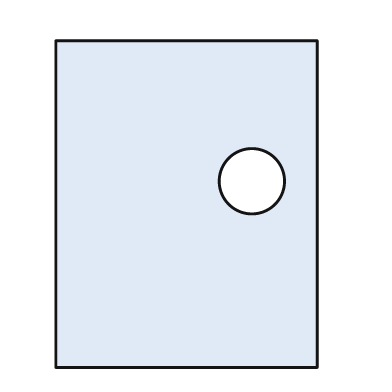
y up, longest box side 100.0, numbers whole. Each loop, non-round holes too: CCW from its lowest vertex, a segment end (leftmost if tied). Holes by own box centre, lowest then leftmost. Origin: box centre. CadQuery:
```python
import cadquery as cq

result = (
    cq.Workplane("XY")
    .moveTo(-40.0, -50.0)
    .lineTo(40.0, -50.0)
    .lineTo(40.0, 50.0)
    .lineTo(-40.0, 50.0)
    .close()
    .moveTo(20.0, 7.0)
    .circle(10.0)
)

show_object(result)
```